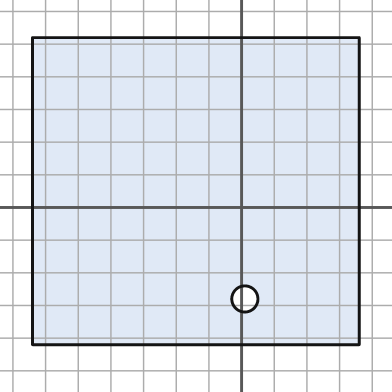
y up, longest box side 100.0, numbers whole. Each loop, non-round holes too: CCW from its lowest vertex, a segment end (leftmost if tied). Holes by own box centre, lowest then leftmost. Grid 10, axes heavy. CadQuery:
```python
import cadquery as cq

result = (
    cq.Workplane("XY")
    .moveTo(-64.0, -42.0)
    .lineTo(36.0, -42.0)
    .lineTo(36.0, 52.0)
    .lineTo(-64.0, 52.0)
    .close()
    .moveTo(1.0, -28.0)
    .circle(4.0)
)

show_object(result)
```